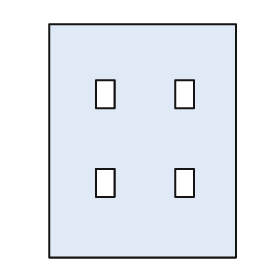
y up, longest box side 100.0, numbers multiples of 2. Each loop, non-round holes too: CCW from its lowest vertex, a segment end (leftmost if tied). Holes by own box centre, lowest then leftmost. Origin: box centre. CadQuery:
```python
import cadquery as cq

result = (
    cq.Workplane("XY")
    .moveTo(-40.0, -50.0)
    .lineTo(40.0, -50.0)
    .lineTo(40.0, 50.0)
    .lineTo(-40.0, 50.0)
    .close()
    .moveTo(-20.0, -24.0)
    .lineTo(-12.0, -24.0)
    .lineTo(-12.0, -12.0)
    .lineTo(-20.0, -12.0)
    .close()
    .moveTo(14.0, -24.0)
    .lineTo(22.0, -24.0)
    .lineTo(22.0, -12.0)
    .lineTo(14.0, -12.0)
    .close()
    .moveTo(-20.0, 14.0)
    .lineTo(-12.0, 14.0)
    .lineTo(-12.0, 26.0)
    .lineTo(-20.0, 26.0)
    .close()
    .moveTo(14.0, 14.0)
    .lineTo(22.0, 14.0)
    .lineTo(22.0, 26.0)
    .lineTo(14.0, 26.0)
    .close()
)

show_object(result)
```